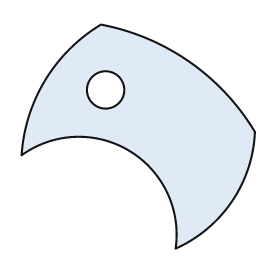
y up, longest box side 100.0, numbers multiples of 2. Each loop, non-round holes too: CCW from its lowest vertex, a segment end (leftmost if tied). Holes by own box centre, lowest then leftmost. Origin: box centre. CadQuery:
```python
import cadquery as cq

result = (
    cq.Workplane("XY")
    .moveTo(16.0, -48.0)
    .threePointArc((40.0, -28.0), (50.0, 2.0))
    .threePointArc((22.0, 32.0), (-16.0, 48.0))
    .threePointArc((-40.0, 24.0), (-50.0, -8.0))
    .threePointArc((-4.0, -6.0), (16.0, -48.0))
    .close()
    .moveTo(-14.0, 20.0)
    .circle(8.0)
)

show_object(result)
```